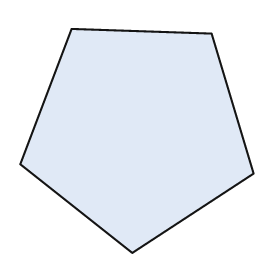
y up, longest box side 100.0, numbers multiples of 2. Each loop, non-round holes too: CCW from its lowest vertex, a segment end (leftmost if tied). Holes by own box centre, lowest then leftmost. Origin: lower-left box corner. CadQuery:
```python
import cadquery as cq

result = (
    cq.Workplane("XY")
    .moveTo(48.0, 0.0)
    .lineTo(100.0, 34.0)
    .lineTo(82.0, 94.0)
    .lineTo(22.0, 96.0)
    .lineTo(0.0, 38.0)
    .close()
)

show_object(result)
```